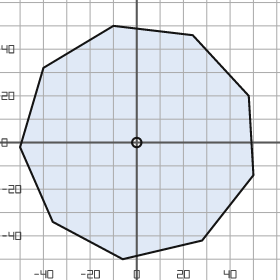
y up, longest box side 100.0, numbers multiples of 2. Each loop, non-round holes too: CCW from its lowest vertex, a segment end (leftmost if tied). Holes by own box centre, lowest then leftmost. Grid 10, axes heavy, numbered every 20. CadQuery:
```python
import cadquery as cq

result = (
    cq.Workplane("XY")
    .moveTo(-6.0, -50.0)
    .lineTo(28.0, -42.0)
    .lineTo(50.0, -14.0)
    .lineTo(48.0, 20.0)
    .lineTo(24.0, 46.0)
    .lineTo(-10.0, 50.0)
    .lineTo(-40.0, 32.0)
    .lineTo(-50.0, -2.0)
    .lineTo(-36.0, -34.0)
    .close()
    .moveTo(0.0, 0.0)
    .circle(2.0)
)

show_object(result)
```